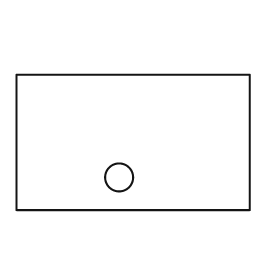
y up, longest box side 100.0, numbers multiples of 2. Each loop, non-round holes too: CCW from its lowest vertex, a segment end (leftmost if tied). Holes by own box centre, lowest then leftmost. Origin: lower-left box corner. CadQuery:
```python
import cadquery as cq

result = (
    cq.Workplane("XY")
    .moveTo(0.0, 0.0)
    .lineTo(100.0, 0.0)
    .lineTo(100.0, 58.0)
    .lineTo(0.0, 58.0)
    .close()
    .moveTo(44.0, 14.0)
    .circle(6.0)
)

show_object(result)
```